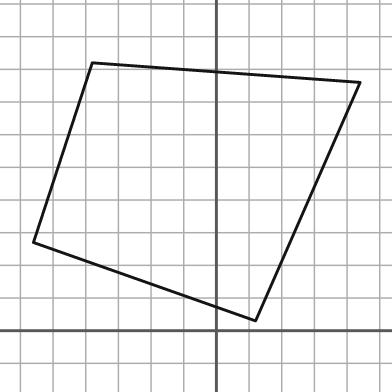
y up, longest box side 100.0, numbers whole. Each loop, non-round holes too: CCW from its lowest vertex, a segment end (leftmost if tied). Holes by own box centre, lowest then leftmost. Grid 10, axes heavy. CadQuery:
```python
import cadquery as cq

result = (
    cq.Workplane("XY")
    .moveTo(12.0, 3.0)
    .lineTo(44.0, 76.0)
    .lineTo(-38.0, 82.0)
    .lineTo(-56.0, 27.0)
    .close()
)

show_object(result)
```